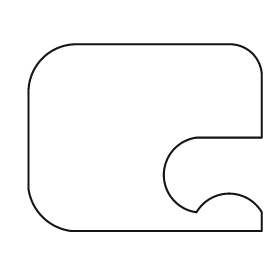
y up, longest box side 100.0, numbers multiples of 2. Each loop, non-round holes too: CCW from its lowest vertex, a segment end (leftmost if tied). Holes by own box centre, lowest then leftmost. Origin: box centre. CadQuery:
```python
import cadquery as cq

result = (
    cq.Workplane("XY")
    .moveTo(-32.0, -40.0)
    .lineTo(50.0, -40.0)
    .lineTo(50.0, -32.0)
    .threePointArc((36.0, -24.0), (22.0, -32.0))
    .threePointArc((8.0, -16.0), (22.0, 0.0))
    .lineTo(50.0, 0.0)
    .lineTo(50.0, 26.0)
    .threePointArc((46.0, 36.0), (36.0, 40.0))
    .lineTo(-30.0, 40.0)
    .threePointArc((-44.0, 34.0), (-50.0, 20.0))
    .lineTo(-50.0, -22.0)
    .threePointArc((-44.0, -34.0), (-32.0, -40.0))
    .close()
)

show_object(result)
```